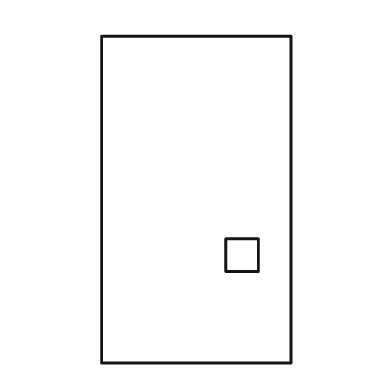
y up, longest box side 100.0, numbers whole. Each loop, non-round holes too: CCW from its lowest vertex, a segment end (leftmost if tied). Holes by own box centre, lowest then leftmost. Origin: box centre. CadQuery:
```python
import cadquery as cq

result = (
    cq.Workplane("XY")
    .moveTo(-29.0, -50.0)
    .lineTo(29.0, -50.0)
    .lineTo(29.0, 50.0)
    .lineTo(-29.0, 50.0)
    .close()
    .moveTo(9.0, -22.0)
    .lineTo(19.0, -22.0)
    .lineTo(19.0, -12.0)
    .lineTo(9.0, -12.0)
    .close()
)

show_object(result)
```